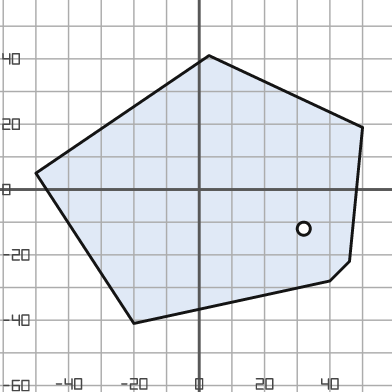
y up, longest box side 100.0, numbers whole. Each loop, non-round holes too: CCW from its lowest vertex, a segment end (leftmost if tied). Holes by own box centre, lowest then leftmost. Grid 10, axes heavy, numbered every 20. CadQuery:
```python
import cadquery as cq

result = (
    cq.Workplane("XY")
    .moveTo(-20.0, -41.0)
    .lineTo(40.0, -28.0)
    .lineTo(46.0, -22.0)
    .lineTo(50.0, 19.0)
    .lineTo(3.0, 41.0)
    .lineTo(-50.0, 5.0)
    .close()
    .moveTo(32.0, -12.0)
    .circle(2.0)
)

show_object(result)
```